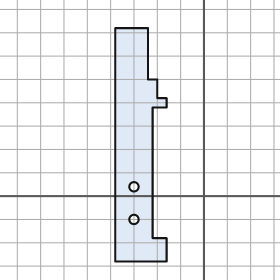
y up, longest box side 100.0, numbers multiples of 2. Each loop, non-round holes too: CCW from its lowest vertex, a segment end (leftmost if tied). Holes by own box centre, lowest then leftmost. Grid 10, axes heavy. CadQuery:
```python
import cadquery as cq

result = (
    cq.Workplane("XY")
    .moveTo(-38.0, -28.0)
    .lineTo(-16.0, -28.0)
    .lineTo(-16.0, -18.0)
    .lineTo(-22.0, -18.0)
    .lineTo(-22.0, 38.0)
    .lineTo(-16.0, 38.0)
    .lineTo(-16.0, 42.0)
    .lineTo(-20.0, 42.0)
    .lineTo(-20.0, 50.0)
    .lineTo(-24.0, 50.0)
    .lineTo(-24.0, 72.0)
    .lineTo(-38.0, 72.0)
    .close()
    .moveTo(-30.0, -10.0)
    .circle(2.0)
    .moveTo(-30.0, 4.0)
    .circle(2.0)
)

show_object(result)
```